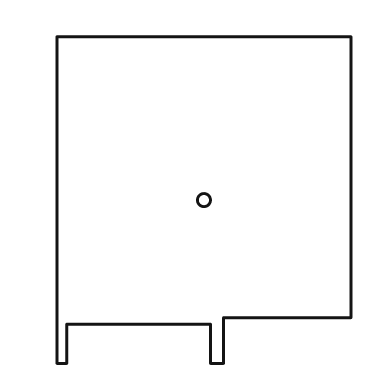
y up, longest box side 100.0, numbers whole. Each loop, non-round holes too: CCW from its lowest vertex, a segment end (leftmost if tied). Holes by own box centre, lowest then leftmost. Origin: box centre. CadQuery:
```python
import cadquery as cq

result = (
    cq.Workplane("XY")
    .moveTo(-45.0, -50.0)
    .lineTo(-42.0, -50.0)
    .lineTo(-42.0, -38.0)
    .lineTo(2.0, -38.0)
    .lineTo(2.0, -50.0)
    .lineTo(6.0, -50.0)
    .lineTo(6.0, -36.0)
    .lineTo(45.0, -36.0)
    .lineTo(45.0, 50.0)
    .lineTo(-45.0, 50.0)
    .close()
    .moveTo(0.0, 0.0)
    .circle(2.0)
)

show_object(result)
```